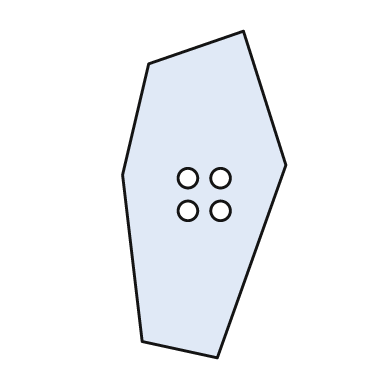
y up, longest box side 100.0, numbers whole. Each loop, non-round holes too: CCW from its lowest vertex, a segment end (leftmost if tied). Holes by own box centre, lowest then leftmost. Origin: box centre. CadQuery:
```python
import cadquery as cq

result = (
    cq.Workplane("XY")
    .moveTo(4.0, -50.0)
    .lineTo(25.0, 9.0)
    .lineTo(12.0, 50.0)
    .lineTo(-17.0, 40.0)
    .lineTo(-25.0, 6.0)
    .lineTo(-19.0, -45.0)
    .close()
    .moveTo(-5.0, -5.0)
    .circle(3.0)
    .moveTo(5.0, -5.0)
    .circle(3.0)
    .moveTo(-5.0, 5.0)
    .circle(3.0)
    .moveTo(5.0, 5.0)
    .circle(3.0)
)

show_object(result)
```